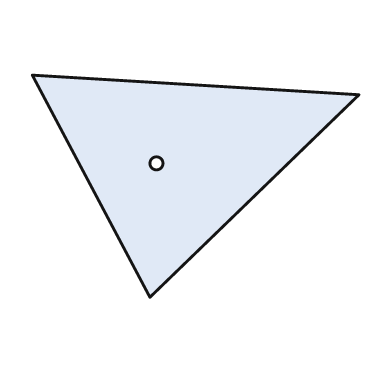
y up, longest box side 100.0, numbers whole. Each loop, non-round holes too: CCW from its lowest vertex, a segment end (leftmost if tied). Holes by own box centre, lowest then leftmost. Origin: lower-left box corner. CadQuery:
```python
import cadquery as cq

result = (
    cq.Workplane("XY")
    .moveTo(36.0, 0.0)
    .lineTo(100.0, 62.0)
    .lineTo(0.0, 68.0)
    .close()
    .moveTo(38.0, 41.0)
    .circle(2.0)
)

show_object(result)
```